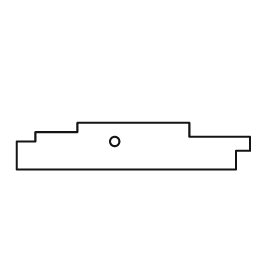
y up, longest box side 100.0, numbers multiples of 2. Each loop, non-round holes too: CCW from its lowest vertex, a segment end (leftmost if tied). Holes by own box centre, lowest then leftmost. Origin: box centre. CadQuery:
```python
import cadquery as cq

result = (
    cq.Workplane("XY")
    .moveTo(-50.0, -10.0)
    .lineTo(44.0, -10.0)
    .lineTo(44.0, -2.0)
    .lineTo(50.0, -2.0)
    .lineTo(50.0, 4.0)
    .lineTo(24.0, 4.0)
    .lineTo(24.0, 10.0)
    .lineTo(-24.0, 10.0)
    .lineTo(-24.0, 6.0)
    .lineTo(-42.0, 6.0)
    .lineTo(-42.0, 2.0)
    .lineTo(-50.0, 2.0)
    .close()
    .moveTo(-8.0, 2.0)
    .circle(2.0)
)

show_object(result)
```